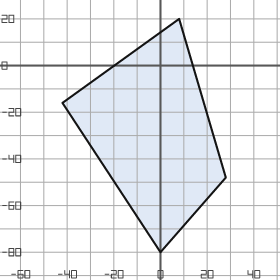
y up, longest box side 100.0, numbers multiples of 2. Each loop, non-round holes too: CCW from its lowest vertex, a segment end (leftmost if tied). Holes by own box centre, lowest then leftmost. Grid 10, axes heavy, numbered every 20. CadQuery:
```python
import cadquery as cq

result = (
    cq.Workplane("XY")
    .moveTo(0.0, -80.0)
    .lineTo(28.0, -48.0)
    .lineTo(8.0, 20.0)
    .lineTo(-42.0, -16.0)
    .close()
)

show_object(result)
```